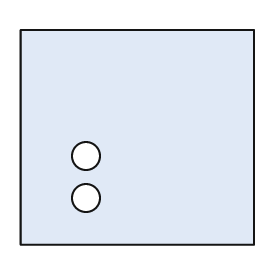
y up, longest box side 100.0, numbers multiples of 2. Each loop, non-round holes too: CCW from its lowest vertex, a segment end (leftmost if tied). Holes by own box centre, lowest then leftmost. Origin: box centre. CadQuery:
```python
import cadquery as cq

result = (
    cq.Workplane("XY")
    .moveTo(-50.0, -46.0)
    .lineTo(50.0, -46.0)
    .lineTo(50.0, 46.0)
    .lineTo(-50.0, 46.0)
    .close()
    .moveTo(-22.0, -26.0)
    .circle(6.0)
    .moveTo(-22.0, -8.0)
    .circle(6.0)
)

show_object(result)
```